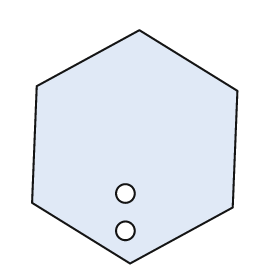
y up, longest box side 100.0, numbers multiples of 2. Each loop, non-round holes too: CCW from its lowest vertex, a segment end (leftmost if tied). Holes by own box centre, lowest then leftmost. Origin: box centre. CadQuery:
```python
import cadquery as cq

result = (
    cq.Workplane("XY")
    .moveTo(-2.0, -50.0)
    .lineTo(42.0, -26.0)
    .lineTo(44.0, 24.0)
    .lineTo(2.0, 50.0)
    .lineTo(-42.0, 26.0)
    .lineTo(-44.0, -24.0)
    .close()
    .moveTo(-4.0, -36.0)
    .circle(4.0)
    .moveTo(-4.0, -20.0)
    .circle(4.0)
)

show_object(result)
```